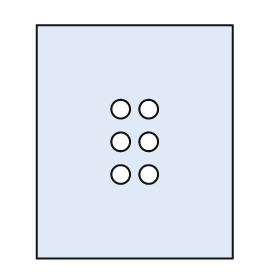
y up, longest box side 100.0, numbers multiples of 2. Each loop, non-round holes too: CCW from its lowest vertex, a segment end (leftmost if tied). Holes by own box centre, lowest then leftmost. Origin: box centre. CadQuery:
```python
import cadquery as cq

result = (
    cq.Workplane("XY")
    .moveTo(-42.0, -50.0)
    .lineTo(42.0, -50.0)
    .lineTo(42.0, 50.0)
    .lineTo(-42.0, 50.0)
    .close()
    .moveTo(-6.0, -14.0)
    .circle(4.0)
    .moveTo(6.0, -14.0)
    .circle(4.0)
    .moveTo(-6.0, 0.0)
    .circle(4.0)
    .moveTo(6.0, 0.0)
    .circle(4.0)
    .moveTo(-6.0, 14.0)
    .circle(4.0)
    .moveTo(6.0, 14.0)
    .circle(4.0)
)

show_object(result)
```